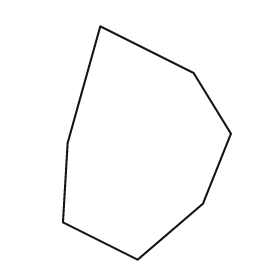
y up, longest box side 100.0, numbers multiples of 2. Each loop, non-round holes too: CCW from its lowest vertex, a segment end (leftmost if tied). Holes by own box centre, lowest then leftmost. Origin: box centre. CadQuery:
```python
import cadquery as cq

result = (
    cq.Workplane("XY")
    .moveTo(-4.0, -50.0)
    .lineTo(24.0, -26.0)
    .lineTo(36.0, 4.0)
    .lineTo(20.0, 30.0)
    .lineTo(-20.0, 50.0)
    .lineTo(-34.0, 0.0)
    .lineTo(-36.0, -34.0)
    .close()
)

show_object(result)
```